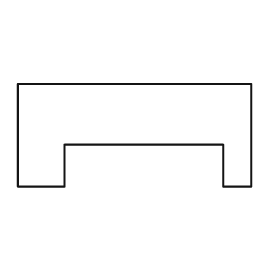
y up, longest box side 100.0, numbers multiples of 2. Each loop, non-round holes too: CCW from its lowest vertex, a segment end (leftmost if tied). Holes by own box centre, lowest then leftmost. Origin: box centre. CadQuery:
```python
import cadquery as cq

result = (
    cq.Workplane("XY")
    .moveTo(-50.0, -22.0)
    .lineTo(-30.0, -22.0)
    .lineTo(-30.0, -4.0)
    .lineTo(38.0, -4.0)
    .lineTo(38.0, -22.0)
    .lineTo(50.0, -22.0)
    .lineTo(50.0, 22.0)
    .lineTo(-50.0, 22.0)
    .close()
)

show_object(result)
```